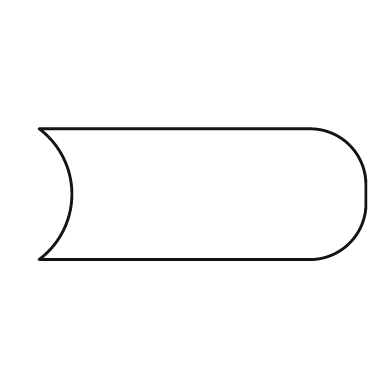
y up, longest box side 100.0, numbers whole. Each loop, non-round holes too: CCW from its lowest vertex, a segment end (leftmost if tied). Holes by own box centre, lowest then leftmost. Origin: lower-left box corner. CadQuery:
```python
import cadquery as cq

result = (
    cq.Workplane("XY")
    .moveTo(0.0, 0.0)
    .lineTo(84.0, 0.0)
    .threePointArc((95.0, 5.0), (100.0, 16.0))
    .lineTo(100.0, 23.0)
    .threePointArc((95.0, 35.0), (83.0, 40.0))
    .lineTo(0.0, 40.0)
    .threePointArc((10.0, 20.0), (0.0, 0.0))
    .close()
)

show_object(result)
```